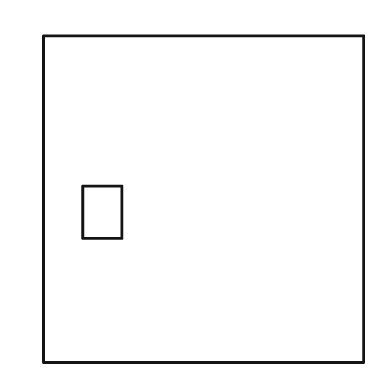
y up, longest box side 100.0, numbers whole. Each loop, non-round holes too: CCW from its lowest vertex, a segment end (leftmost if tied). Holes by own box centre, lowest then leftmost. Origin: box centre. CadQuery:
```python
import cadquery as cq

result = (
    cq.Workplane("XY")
    .moveTo(-49.0, -50.0)
    .lineTo(49.0, -50.0)
    .lineTo(49.0, 50.0)
    .lineTo(-49.0, 50.0)
    .close()
    .moveTo(-37.0, -12.0)
    .lineTo(-25.0, -12.0)
    .lineTo(-25.0, 4.0)
    .lineTo(-37.0, 4.0)
    .close()
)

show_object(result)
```